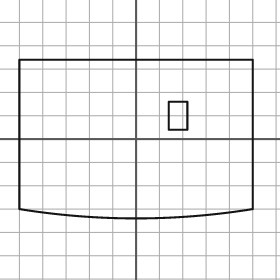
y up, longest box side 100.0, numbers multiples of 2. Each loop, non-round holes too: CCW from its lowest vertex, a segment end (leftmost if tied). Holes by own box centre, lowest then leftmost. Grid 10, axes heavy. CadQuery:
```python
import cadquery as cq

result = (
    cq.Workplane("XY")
    .moveTo(-50.0, -30.0)
    .threePointArc((0.0, -34.0), (50.0, -30.0))
    .lineTo(50.0, 34.0)
    .lineTo(-50.0, 34.0)
    .close()
    .moveTo(14.0, 4.0)
    .lineTo(22.0, 4.0)
    .lineTo(22.0, 16.0)
    .lineTo(14.0, 16.0)
    .close()
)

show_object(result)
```